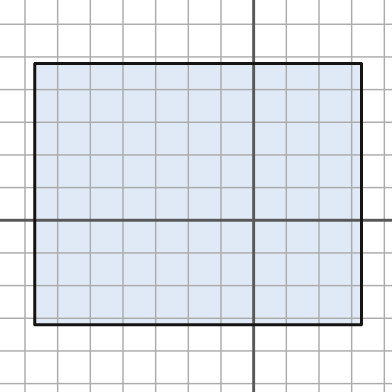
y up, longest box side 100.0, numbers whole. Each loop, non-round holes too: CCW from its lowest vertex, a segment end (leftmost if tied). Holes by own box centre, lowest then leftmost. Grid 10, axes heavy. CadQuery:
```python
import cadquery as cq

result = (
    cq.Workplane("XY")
    .moveTo(-67.0, -32.0)
    .lineTo(33.0, -32.0)
    .lineTo(33.0, 48.0)
    .lineTo(-67.0, 48.0)
    .close()
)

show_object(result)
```